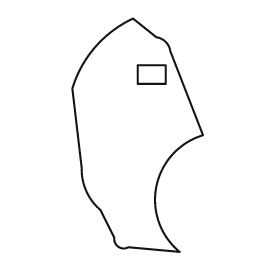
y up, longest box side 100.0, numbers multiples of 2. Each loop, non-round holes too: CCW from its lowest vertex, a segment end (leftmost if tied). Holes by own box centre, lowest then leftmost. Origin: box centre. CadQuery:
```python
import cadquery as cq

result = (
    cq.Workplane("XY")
    .moveTo(18.0, -50.0)
    .threePointArc((8.0, -22.0), (28.0, 0.0))
    .lineTo(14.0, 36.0)
    .threePointArc((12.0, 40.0), (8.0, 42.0))
    .lineTo(-2.0, 50.0)
    .threePointArc((-18.0, 38.0), (-28.0, 20.0))
    .lineTo(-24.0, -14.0)
    .threePointArc((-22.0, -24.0), (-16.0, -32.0))
    .lineTo(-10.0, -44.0)
    .threePointArc((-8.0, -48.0), (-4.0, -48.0))
    .close()
    .moveTo(0.0, 22.0)
    .lineTo(12.0, 22.0)
    .lineTo(12.0, 30.0)
    .lineTo(0.0, 30.0)
    .close()
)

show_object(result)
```